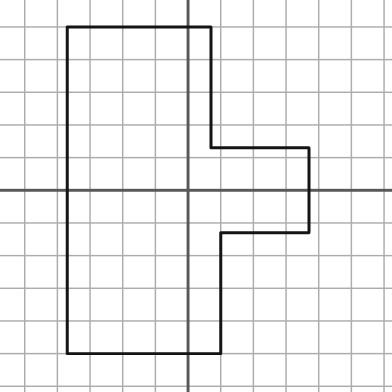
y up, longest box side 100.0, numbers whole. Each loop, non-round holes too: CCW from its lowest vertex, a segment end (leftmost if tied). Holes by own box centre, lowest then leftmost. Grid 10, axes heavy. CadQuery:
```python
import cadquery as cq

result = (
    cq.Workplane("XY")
    .moveTo(-37.0, -50.0)
    .lineTo(10.0, -50.0)
    .lineTo(10.0, -13.0)
    .lineTo(37.0, -13.0)
    .lineTo(37.0, 13.0)
    .lineTo(7.0, 13.0)
    .lineTo(7.0, 50.0)
    .lineTo(-37.0, 50.0)
    .close()
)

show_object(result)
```